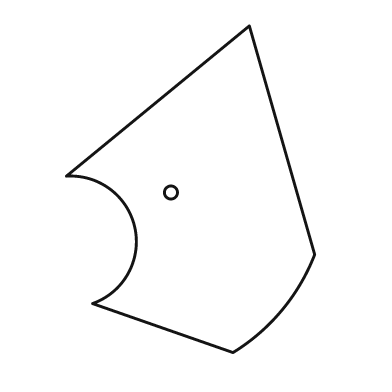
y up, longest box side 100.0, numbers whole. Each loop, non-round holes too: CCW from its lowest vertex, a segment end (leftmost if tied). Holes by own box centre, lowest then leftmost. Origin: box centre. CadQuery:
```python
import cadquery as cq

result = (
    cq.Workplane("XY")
    .moveTo(13.0, -50.0)
    .threePointArc((28.0, -37.0), (38.0, -20.0))
    .lineTo(18.0, 50.0)
    .lineTo(-38.0, 4.0)
    .threePointArc((-17.0, -12.0), (-30.0, -35.0))
    .close()
    .moveTo(-6.0, -1.0)
    .circle(2.0)
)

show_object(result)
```